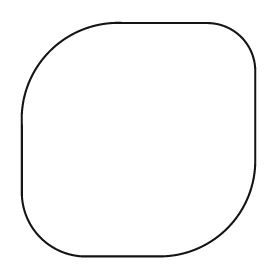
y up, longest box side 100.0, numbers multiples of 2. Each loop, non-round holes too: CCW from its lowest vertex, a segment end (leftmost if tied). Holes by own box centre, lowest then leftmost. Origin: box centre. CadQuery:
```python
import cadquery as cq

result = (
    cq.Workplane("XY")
    .moveTo(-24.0, -50.0)
    .lineTo(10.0, -50.0)
    .threePointArc((38.0, -38.0), (50.0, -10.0))
    .lineTo(50.0, 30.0)
    .threePointArc((44.0, 44.0), (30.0, 50.0))
    .lineTo(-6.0, 50.0)
    .threePointArc((-38.0, 38.0), (-50.0, 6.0))
    .lineTo(-50.0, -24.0)
    .threePointArc((-42.0, -42.0), (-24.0, -50.0))
    .close()
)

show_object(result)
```